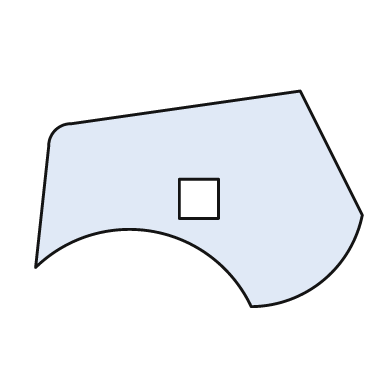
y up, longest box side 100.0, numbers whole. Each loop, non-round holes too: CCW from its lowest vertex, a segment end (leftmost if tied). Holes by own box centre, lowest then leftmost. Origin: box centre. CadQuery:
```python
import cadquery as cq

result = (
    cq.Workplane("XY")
    .moveTo(16.0, -33.0)
    .threePointArc((38.0, -25.0), (50.0, -5.0))
    .lineTo(31.0, 33.0)
    .lineTo(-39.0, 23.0)
    .threePointArc((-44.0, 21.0), (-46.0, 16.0))
    .lineTo(-50.0, -21.0)
    .threePointArc((-14.0, -10.0), (16.0, -33.0))
    .close()
    .moveTo(-6.0, -6.0)
    .lineTo(6.0, -6.0)
    .lineTo(6.0, 6.0)
    .lineTo(-6.0, 6.0)
    .close()
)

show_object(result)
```